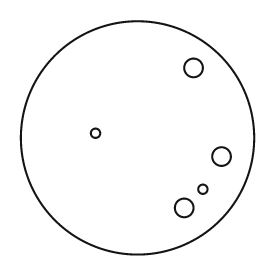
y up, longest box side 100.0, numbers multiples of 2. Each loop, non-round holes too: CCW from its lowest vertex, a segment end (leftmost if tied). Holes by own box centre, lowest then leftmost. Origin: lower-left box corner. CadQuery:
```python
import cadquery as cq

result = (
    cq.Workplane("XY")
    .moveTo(50.0, 50.0)
    .circle(50.0)
    .moveTo(70.0, 20.0)
    .circle(4.0)
    .moveTo(78.0, 28.0)
    .circle(2.0)
    .moveTo(86.0, 42.0)
    .circle(4.0)
    .moveTo(32.0, 52.0)
    .circle(2.0)
    .moveTo(74.0, 80.0)
    .circle(4.0)
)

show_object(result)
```